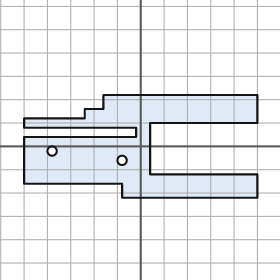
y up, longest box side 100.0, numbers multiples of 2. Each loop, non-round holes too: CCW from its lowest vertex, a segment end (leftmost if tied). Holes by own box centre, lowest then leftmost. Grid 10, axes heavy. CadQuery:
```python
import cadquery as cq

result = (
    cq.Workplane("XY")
    .moveTo(-8.0, -22.0)
    .lineTo(50.0, -22.0)
    .lineTo(50.0, -12.0)
    .lineTo(4.0, -12.0)
    .lineTo(4.0, 10.0)
    .lineTo(50.0, 10.0)
    .lineTo(50.0, 22.0)
    .lineTo(-16.0, 22.0)
    .lineTo(-16.0, 16.0)
    .lineTo(-24.0, 16.0)
    .lineTo(-24.0, 12.0)
    .lineTo(-50.0, 12.0)
    .lineTo(-50.0, 8.0)
    .lineTo(-2.0, 8.0)
    .lineTo(-2.0, 4.0)
    .lineTo(-50.0, 4.0)
    .lineTo(-50.0, -16.0)
    .lineTo(-8.0, -16.0)
    .close()
    .moveTo(-8.0, -6.0)
    .circle(2.0)
    .moveTo(-38.0, -2.0)
    .circle(2.0)
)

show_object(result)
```